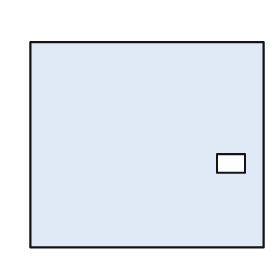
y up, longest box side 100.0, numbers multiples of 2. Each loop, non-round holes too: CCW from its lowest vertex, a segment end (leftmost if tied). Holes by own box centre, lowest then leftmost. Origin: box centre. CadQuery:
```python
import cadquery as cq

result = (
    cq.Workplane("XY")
    .moveTo(-50.0, -44.0)
    .lineTo(50.0, -44.0)
    .lineTo(50.0, 44.0)
    .lineTo(-50.0, 44.0)
    .close()
    .moveTo(30.0, -12.0)
    .lineTo(42.0, -12.0)
    .lineTo(42.0, -4.0)
    .lineTo(30.0, -4.0)
    .close()
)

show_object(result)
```